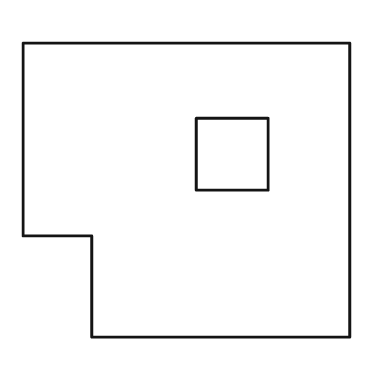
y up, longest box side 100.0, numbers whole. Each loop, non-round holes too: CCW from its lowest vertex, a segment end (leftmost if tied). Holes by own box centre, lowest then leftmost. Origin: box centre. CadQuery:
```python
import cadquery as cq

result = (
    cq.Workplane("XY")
    .moveTo(-29.0, -45.0)
    .lineTo(50.0, -45.0)
    .lineTo(50.0, 45.0)
    .lineTo(-50.0, 45.0)
    .lineTo(-50.0, -14.0)
    .lineTo(-29.0, -14.0)
    .close()
    .moveTo(3.0, 0.0)
    .lineTo(25.0, 0.0)
    .lineTo(25.0, 22.0)
    .lineTo(3.0, 22.0)
    .close()
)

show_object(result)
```